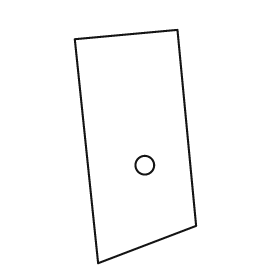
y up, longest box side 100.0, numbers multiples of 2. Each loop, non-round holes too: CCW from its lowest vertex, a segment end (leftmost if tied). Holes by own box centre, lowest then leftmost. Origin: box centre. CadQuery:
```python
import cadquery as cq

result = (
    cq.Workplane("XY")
    .moveTo(-16.0, -50.0)
    .lineTo(26.0, -34.0)
    .lineTo(18.0, 50.0)
    .lineTo(-26.0, 46.0)
    .close()
    .moveTo(4.0, -8.0)
    .circle(4.0)
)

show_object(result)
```